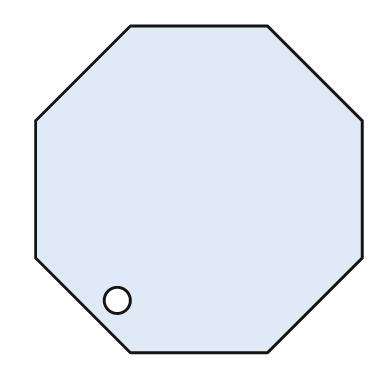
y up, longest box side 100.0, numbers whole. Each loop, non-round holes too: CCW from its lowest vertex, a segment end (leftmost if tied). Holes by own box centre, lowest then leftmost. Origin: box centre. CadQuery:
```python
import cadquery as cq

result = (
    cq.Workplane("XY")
    .moveTo(-21.0, -50.0)
    .lineTo(21.0, -50.0)
    .lineTo(50.0, -21.0)
    .lineTo(50.0, 21.0)
    .lineTo(21.0, 50.0)
    .lineTo(-21.0, 50.0)
    .lineTo(-50.0, 21.0)
    .lineTo(-50.0, -21.0)
    .close()
    .moveTo(-25.0, -34.0)
    .circle(4.0)
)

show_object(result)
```